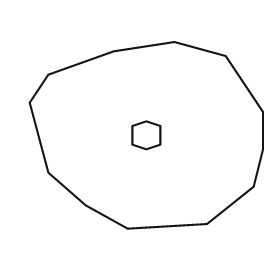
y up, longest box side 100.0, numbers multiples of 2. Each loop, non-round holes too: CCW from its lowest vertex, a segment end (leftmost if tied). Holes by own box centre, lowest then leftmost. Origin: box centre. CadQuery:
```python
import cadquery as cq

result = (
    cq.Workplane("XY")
    .moveTo(-8.0, -40.0)
    .lineTo(26.0, -38.0)
    .lineTo(46.0, -22.0)
    .lineTo(50.0, -6.0)
    .lineTo(50.0, 10.0)
    .lineTo(34.0, 34.0)
    .lineTo(12.0, 40.0)
    .lineTo(-14.0, 36.0)
    .lineTo(-42.0, 26.0)
    .lineTo(-50.0, 14.0)
    .lineTo(-42.0, -16.0)
    .lineTo(-26.0, -30.0)
    .close()
    .moveTo(0.0, -6.0)
    .lineTo(6.0, -4.0)
    .lineTo(6.0, 4.0)
    .lineTo(0.0, 6.0)
    .lineTo(-6.0, 4.0)
    .lineTo(-6.0, -4.0)
    .close()
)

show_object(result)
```